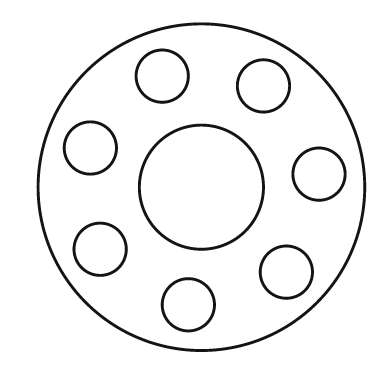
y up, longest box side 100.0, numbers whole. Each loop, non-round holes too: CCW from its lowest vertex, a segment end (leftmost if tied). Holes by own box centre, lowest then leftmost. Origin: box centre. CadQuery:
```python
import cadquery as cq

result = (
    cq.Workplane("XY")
    .moveTo(0.0, 0.0)
    .circle(50.0)
    .moveTo(-4.0, -36.0)
    .circle(8.0)
    .moveTo(26.0, -26.0)
    .circle(8.0)
    .moveTo(-31.0, -19.0)
    .circle(8.0)
    .moveTo(0.0, 0.0)
    .circle(19.0)
    .moveTo(36.0, 4.0)
    .circle(8.0)
    .moveTo(-34.0, 12.0)
    .circle(8.0)
    .moveTo(19.0, 31.0)
    .circle(8.0)
    .moveTo(-12.0, 34.0)
    .circle(8.0)
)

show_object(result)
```